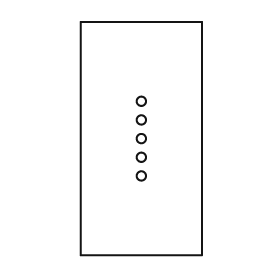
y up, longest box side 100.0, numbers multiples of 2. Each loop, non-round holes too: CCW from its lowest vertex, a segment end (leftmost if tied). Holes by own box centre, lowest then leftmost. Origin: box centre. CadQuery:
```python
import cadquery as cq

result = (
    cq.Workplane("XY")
    .moveTo(-26.0, -50.0)
    .lineTo(26.0, -50.0)
    .lineTo(26.0, 50.0)
    .lineTo(-26.0, 50.0)
    .close()
    .moveTo(0.0, -16.0)
    .circle(2.0)
    .moveTo(0.0, -8.0)
    .circle(2.0)
    .moveTo(0.0, 0.0)
    .circle(2.0)
    .moveTo(0.0, 8.0)
    .circle(2.0)
    .moveTo(0.0, 16.0)
    .circle(2.0)
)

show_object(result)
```